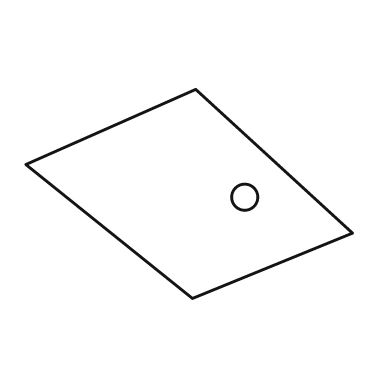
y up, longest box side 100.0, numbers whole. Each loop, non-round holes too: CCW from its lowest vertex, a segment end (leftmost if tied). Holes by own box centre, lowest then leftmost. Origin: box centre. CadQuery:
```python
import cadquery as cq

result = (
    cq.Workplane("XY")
    .moveTo(1.0, -32.0)
    .lineTo(50.0, -12.0)
    .lineTo(2.0, 32.0)
    .lineTo(-50.0, 9.0)
    .close()
    .moveTo(17.0, -1.0)
    .circle(4.0)
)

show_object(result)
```